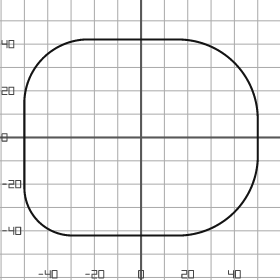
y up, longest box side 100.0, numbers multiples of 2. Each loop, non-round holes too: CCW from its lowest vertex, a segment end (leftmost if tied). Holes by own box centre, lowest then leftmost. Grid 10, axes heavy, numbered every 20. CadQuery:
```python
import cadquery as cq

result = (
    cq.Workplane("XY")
    .moveTo(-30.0, -42.0)
    .lineTo(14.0, -42.0)
    .threePointArc((40.0, -32.0), (50.0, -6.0))
    .lineTo(50.0, 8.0)
    .threePointArc((40.0, 32.0), (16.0, 42.0))
    .lineTo(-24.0, 42.0)
    .threePointArc((-42.0, 34.0), (-50.0, 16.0))
    .lineTo(-50.0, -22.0)
    .threePointArc((-44.0, -36.0), (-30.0, -42.0))
    .close()
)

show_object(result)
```